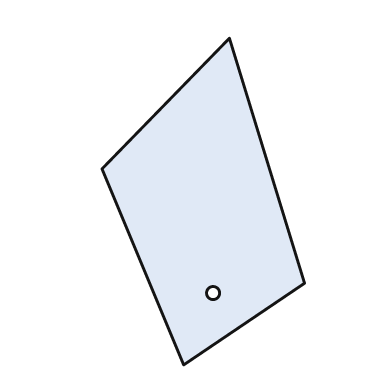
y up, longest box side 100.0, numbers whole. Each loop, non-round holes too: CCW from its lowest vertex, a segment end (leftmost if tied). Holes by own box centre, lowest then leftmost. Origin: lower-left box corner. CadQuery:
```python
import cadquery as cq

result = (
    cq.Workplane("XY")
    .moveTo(25.0, 0.0)
    .lineTo(62.0, 25.0)
    .lineTo(39.0, 100.0)
    .lineTo(0.0, 60.0)
    .close()
    .moveTo(34.0, 22.0)
    .circle(2.0)
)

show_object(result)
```